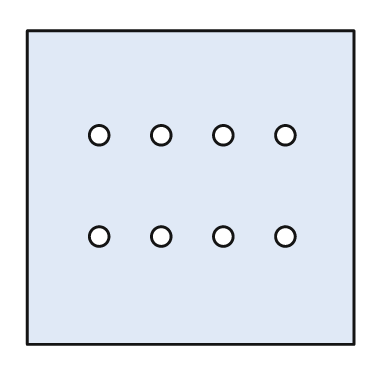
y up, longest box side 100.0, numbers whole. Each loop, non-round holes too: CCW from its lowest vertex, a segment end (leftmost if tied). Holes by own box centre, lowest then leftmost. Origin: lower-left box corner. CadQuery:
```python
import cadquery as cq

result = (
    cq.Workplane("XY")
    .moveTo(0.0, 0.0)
    .lineTo(100.0, 0.0)
    .lineTo(100.0, 96.0)
    .lineTo(0.0, 96.0)
    .close()
    .moveTo(22.0, 33.0)
    .circle(3.0)
    .moveTo(41.0, 33.0)
    .circle(3.0)
    .moveTo(60.0, 33.0)
    .circle(3.0)
    .moveTo(79.0, 33.0)
    .circle(3.0)
    .moveTo(22.0, 64.0)
    .circle(3.0)
    .moveTo(41.0, 64.0)
    .circle(3.0)
    .moveTo(60.0, 64.0)
    .circle(3.0)
    .moveTo(79.0, 64.0)
    .circle(3.0)
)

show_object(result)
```